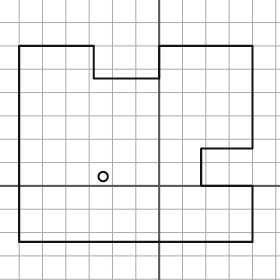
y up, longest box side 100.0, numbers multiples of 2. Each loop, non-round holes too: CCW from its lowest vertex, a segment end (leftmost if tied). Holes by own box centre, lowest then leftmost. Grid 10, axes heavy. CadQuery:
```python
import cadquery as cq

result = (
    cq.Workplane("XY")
    .moveTo(-60.0, -24.0)
    .lineTo(40.0, -24.0)
    .lineTo(40.0, 0.0)
    .lineTo(18.0, 0.0)
    .lineTo(18.0, 16.0)
    .lineTo(40.0, 16.0)
    .lineTo(40.0, 60.0)
    .lineTo(0.0, 60.0)
    .lineTo(0.0, 46.0)
    .lineTo(-28.0, 46.0)
    .lineTo(-28.0, 60.0)
    .lineTo(-60.0, 60.0)
    .close()
    .moveTo(-24.0, 4.0)
    .circle(2.0)
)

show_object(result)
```